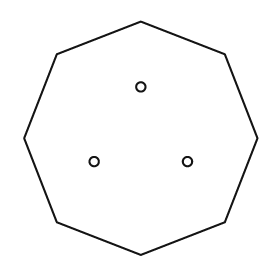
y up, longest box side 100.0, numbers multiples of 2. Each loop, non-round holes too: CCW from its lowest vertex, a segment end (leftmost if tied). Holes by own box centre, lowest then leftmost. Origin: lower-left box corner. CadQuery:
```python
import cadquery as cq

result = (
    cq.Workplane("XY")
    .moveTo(50.0, 0.0)
    .lineTo(86.0, 14.0)
    .lineTo(100.0, 50.0)
    .lineTo(86.0, 86.0)
    .lineTo(50.0, 100.0)
    .lineTo(14.0, 86.0)
    .lineTo(0.0, 50.0)
    .lineTo(14.0, 14.0)
    .close()
    .moveTo(30.0, 40.0)
    .circle(2.0)
    .moveTo(70.0, 40.0)
    .circle(2.0)
    .moveTo(50.0, 72.0)
    .circle(2.0)
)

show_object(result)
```